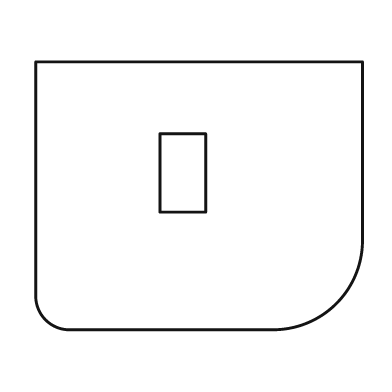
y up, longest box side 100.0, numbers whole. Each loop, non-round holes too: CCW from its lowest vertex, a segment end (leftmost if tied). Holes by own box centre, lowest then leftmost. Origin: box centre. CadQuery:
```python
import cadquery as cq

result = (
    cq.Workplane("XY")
    .moveTo(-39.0, -41.0)
    .lineTo(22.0, -41.0)
    .threePointArc((42.0, -33.0), (50.0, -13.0))
    .lineTo(50.0, 41.0)
    .lineTo(-50.0, 41.0)
    .lineTo(-50.0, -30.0)
    .threePointArc((-47.0, -38.0), (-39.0, -41.0))
    .close()
    .moveTo(-12.0, -5.0)
    .lineTo(2.0, -5.0)
    .lineTo(2.0, 19.0)
    .lineTo(-12.0, 19.0)
    .close()
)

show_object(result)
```